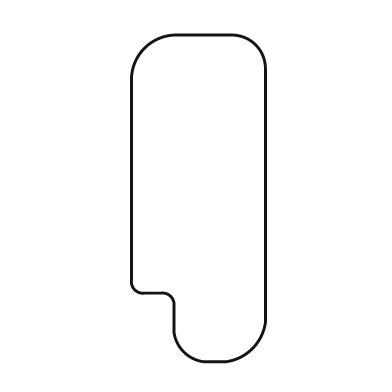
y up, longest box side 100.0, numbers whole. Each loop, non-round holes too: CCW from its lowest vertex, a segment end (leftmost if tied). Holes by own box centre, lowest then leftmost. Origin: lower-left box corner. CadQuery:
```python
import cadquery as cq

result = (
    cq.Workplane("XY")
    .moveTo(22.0, 0.0)
    .lineTo(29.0, 0.0)
    .threePointArc((37.0, 4.0), (41.0, 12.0))
    .lineTo(41.0, 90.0)
    .threePointArc((38.0, 97.0), (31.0, 100.0))
    .lineTo(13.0, 100.0)
    .threePointArc((4.0, 96.0), (0.0, 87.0))
    .lineTo(0.0, 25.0)
    .threePointArc((1.0, 22.0), (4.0, 21.0))
    .lineTo(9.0, 21.0)
    .threePointArc((12.0, 20.0), (13.0, 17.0))
    .lineTo(13.0, 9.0)
    .threePointArc((16.0, 3.0), (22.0, 0.0))
    .close()
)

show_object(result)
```